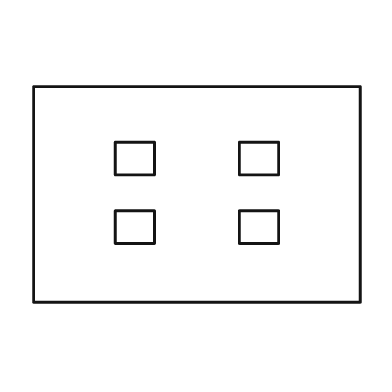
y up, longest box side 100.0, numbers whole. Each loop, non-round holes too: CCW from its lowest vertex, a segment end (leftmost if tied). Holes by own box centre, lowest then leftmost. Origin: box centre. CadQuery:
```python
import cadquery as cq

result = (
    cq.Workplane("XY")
    .moveTo(-50.0, -33.0)
    .lineTo(50.0, -33.0)
    .lineTo(50.0, 33.0)
    .lineTo(-50.0, 33.0)
    .close()
    .moveTo(-25.0, -15.0)
    .lineTo(-13.0, -15.0)
    .lineTo(-13.0, -5.0)
    .lineTo(-25.0, -5.0)
    .close()
    .moveTo(13.0, -15.0)
    .lineTo(25.0, -15.0)
    .lineTo(25.0, -5.0)
    .lineTo(13.0, -5.0)
    .close()
    .moveTo(-25.0, 6.0)
    .lineTo(-13.0, 6.0)
    .lineTo(-13.0, 16.0)
    .lineTo(-25.0, 16.0)
    .close()
    .moveTo(13.0, 6.0)
    .lineTo(25.0, 6.0)
    .lineTo(25.0, 16.0)
    .lineTo(13.0, 16.0)
    .close()
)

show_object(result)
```